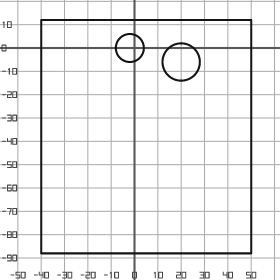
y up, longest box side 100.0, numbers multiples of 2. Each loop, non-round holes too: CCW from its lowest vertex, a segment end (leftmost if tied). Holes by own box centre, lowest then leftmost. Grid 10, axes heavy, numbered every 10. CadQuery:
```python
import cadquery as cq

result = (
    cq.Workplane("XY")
    .moveTo(-40.0, -88.0)
    .lineTo(50.0, -88.0)
    .lineTo(50.0, 12.0)
    .lineTo(-40.0, 12.0)
    .close()
    .moveTo(20.0, -6.0)
    .circle(8.0)
    .moveTo(-2.0, 0.0)
    .circle(6.0)
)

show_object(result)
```